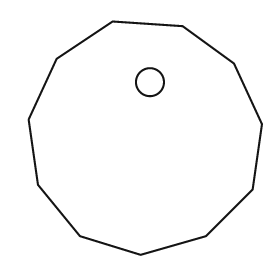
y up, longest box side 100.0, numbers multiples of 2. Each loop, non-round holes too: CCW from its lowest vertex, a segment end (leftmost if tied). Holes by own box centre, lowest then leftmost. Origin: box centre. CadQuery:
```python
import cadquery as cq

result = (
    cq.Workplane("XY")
    .moveTo(-2.0, -50.0)
    .lineTo(26.0, -42.0)
    .lineTo(46.0, -22.0)
    .lineTo(50.0, 6.0)
    .lineTo(38.0, 32.0)
    .lineTo(16.0, 48.0)
    .lineTo(-14.0, 50.0)
    .lineTo(-38.0, 34.0)
    .lineTo(-50.0, 8.0)
    .lineTo(-46.0, -20.0)
    .lineTo(-28.0, -42.0)
    .close()
    .moveTo(2.0, 24.0)
    .circle(6.0)
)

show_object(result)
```